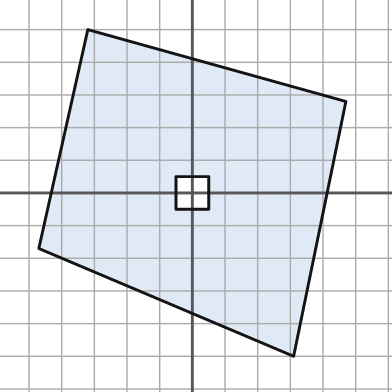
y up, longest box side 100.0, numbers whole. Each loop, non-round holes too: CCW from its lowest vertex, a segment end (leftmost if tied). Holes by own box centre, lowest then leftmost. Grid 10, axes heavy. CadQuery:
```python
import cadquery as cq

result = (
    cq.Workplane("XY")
    .moveTo(31.0, -50.0)
    .lineTo(47.0, 28.0)
    .lineTo(-32.0, 50.0)
    .lineTo(-47.0, -17.0)
    .close()
    .moveTo(-5.0, -5.0)
    .lineTo(5.0, -5.0)
    .lineTo(5.0, 5.0)
    .lineTo(-5.0, 5.0)
    .close()
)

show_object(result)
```